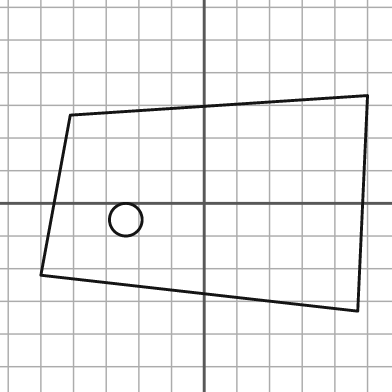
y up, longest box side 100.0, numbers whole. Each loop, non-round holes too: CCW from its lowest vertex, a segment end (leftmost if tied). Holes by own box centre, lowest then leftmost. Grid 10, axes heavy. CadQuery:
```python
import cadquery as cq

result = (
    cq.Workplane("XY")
    .moveTo(47.0, -33.0)
    .lineTo(50.0, 33.0)
    .lineTo(-41.0, 27.0)
    .lineTo(-50.0, -22.0)
    .close()
    .moveTo(-24.0, -5.0)
    .circle(5.0)
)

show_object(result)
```